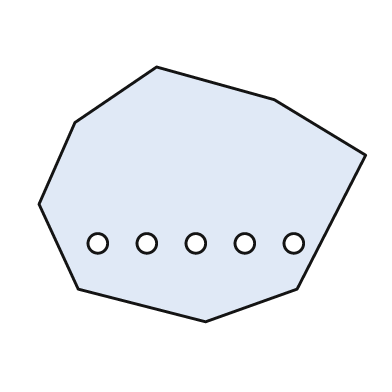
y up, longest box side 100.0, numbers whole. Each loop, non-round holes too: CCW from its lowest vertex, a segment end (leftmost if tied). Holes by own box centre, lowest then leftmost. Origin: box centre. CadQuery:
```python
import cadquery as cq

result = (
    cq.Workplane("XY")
    .moveTo(1.0, -39.0)
    .lineTo(29.0, -29.0)
    .lineTo(50.0, 12.0)
    .lineTo(22.0, 29.0)
    .lineTo(-14.0, 39.0)
    .lineTo(-39.0, 22.0)
    .lineTo(-50.0, -3.0)
    .lineTo(-38.0, -29.0)
    .close()
    .moveTo(-32.0, -15.0)
    .circle(3.0)
    .moveTo(-17.0, -15.0)
    .circle(3.0)
    .moveTo(-2.0, -15.0)
    .circle(3.0)
    .moveTo(13.0, -15.0)
    .circle(3.0)
    .moveTo(28.0, -15.0)
    .circle(3.0)
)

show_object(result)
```